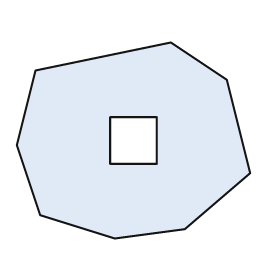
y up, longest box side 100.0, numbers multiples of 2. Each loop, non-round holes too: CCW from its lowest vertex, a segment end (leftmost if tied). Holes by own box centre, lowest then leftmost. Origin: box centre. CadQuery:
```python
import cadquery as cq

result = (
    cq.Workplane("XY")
    .moveTo(-8.0, -42.0)
    .lineTo(22.0, -38.0)
    .lineTo(50.0, -14.0)
    .lineTo(40.0, 26.0)
    .lineTo(16.0, 42.0)
    .lineTo(-42.0, 30.0)
    .lineTo(-50.0, -2.0)
    .lineTo(-40.0, -32.0)
    .close()
    .moveTo(-10.0, -10.0)
    .lineTo(10.0, -10.0)
    .lineTo(10.0, 10.0)
    .lineTo(-10.0, 10.0)
    .close()
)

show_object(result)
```